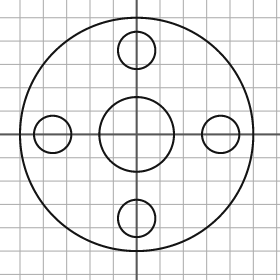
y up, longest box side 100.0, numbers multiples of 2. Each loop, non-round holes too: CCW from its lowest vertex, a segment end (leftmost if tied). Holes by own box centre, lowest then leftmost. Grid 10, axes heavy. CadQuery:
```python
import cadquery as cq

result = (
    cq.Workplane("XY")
    .moveTo(0.0, 0.0)
    .circle(50.0)
    .moveTo(0.0, -36.0)
    .circle(8.0)
    .moveTo(-36.0, 0.0)
    .circle(8.0)
    .moveTo(0.0, 0.0)
    .circle(16.0)
    .moveTo(36.0, 0.0)
    .circle(8.0)
    .moveTo(0.0, 36.0)
    .circle(8.0)
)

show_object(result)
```